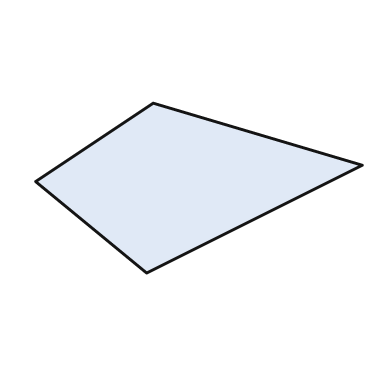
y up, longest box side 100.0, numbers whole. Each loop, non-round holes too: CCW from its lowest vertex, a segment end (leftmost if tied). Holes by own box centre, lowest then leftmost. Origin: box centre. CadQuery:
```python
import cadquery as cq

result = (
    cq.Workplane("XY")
    .moveTo(-16.0, -26.0)
    .lineTo(50.0, 7.0)
    .lineTo(-14.0, 26.0)
    .lineTo(-50.0, 2.0)
    .close()
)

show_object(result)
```